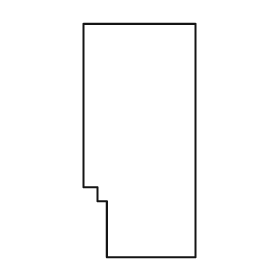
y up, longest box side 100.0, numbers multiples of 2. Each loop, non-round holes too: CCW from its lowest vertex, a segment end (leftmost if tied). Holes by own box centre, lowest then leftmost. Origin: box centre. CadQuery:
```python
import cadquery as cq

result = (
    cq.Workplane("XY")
    .moveTo(-14.0, -50.0)
    .lineTo(24.0, -50.0)
    .lineTo(24.0, 50.0)
    .lineTo(-24.0, 50.0)
    .lineTo(-24.0, -20.0)
    .lineTo(-18.0, -20.0)
    .lineTo(-18.0, -26.0)
    .lineTo(-14.0, -26.0)
    .close()
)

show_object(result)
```